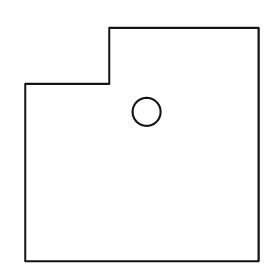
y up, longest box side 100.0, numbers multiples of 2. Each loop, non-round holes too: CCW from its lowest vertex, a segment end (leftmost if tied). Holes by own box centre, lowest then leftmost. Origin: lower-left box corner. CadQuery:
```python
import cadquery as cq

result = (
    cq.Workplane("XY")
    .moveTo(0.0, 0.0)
    .lineTo(100.0, 0.0)
    .lineTo(100.0, 100.0)
    .lineTo(36.0, 100.0)
    .lineTo(36.0, 76.0)
    .lineTo(0.0, 76.0)
    .close()
    .moveTo(52.0, 64.0)
    .circle(6.0)
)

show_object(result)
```